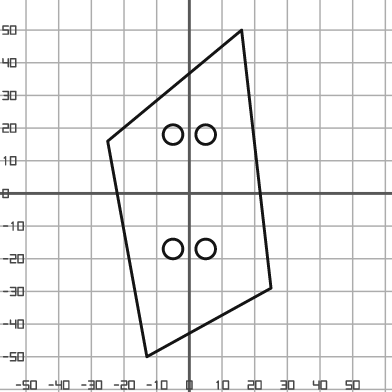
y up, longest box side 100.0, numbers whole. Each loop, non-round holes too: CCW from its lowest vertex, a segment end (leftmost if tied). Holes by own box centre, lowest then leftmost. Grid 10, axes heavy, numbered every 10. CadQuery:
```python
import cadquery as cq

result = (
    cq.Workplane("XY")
    .moveTo(-13.0, -50.0)
    .lineTo(25.0, -29.0)
    .lineTo(16.0, 50.0)
    .lineTo(-25.0, 16.0)
    .close()
    .moveTo(-5.0, -17.0)
    .circle(3.0)
    .moveTo(5.0, -17.0)
    .circle(3.0)
    .moveTo(-5.0, 18.0)
    .circle(3.0)
    .moveTo(5.0, 18.0)
    .circle(3.0)
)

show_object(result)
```